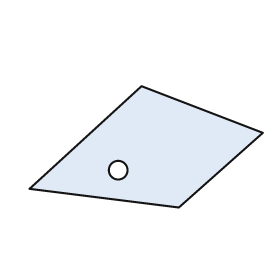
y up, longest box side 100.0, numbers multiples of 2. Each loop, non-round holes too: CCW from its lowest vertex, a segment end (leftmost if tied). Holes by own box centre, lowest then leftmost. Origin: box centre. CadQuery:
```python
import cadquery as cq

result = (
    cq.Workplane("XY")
    .moveTo(14.0, -26.0)
    .lineTo(50.0, 6.0)
    .lineTo(-2.0, 26.0)
    .lineTo(-50.0, -18.0)
    .close()
    .moveTo(-12.0, -10.0)
    .circle(4.0)
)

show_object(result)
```